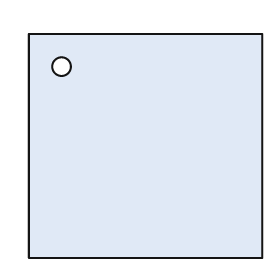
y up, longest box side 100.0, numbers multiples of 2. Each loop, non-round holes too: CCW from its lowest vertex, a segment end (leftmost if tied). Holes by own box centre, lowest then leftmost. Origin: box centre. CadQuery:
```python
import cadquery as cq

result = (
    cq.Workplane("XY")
    .moveTo(-50.0, -48.0)
    .lineTo(50.0, -48.0)
    .lineTo(50.0, 48.0)
    .lineTo(-50.0, 48.0)
    .close()
    .moveTo(-36.0, 34.0)
    .circle(4.0)
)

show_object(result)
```